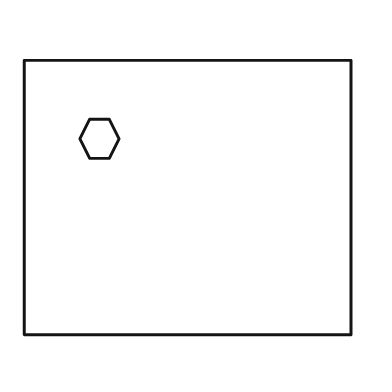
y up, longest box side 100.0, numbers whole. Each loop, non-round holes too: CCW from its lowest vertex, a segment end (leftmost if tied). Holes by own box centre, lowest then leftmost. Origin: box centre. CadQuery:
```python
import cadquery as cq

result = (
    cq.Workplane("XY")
    .moveTo(-50.0, -42.0)
    .lineTo(50.0, -42.0)
    .lineTo(50.0, 42.0)
    .lineTo(-50.0, 42.0)
    .close()
    .moveTo(-30.0, 12.0)
    .lineTo(-24.0, 12.0)
    .lineTo(-21.0, 18.0)
    .lineTo(-24.0, 24.0)
    .lineTo(-30.0, 24.0)
    .lineTo(-33.0, 18.0)
    .close()
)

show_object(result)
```